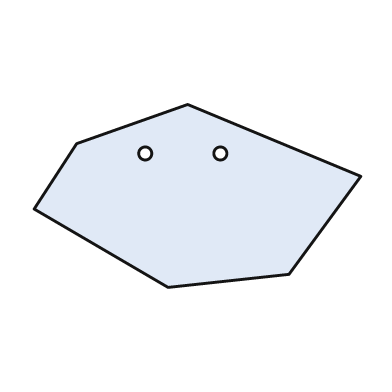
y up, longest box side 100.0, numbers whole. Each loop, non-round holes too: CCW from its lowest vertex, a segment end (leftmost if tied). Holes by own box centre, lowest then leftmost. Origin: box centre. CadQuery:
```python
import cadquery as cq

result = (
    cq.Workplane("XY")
    .moveTo(-9.0, -28.0)
    .lineTo(28.0, -24.0)
    .lineTo(50.0, 6.0)
    .lineTo(-3.0, 28.0)
    .lineTo(-37.0, 16.0)
    .lineTo(-50.0, -4.0)
    .close()
    .moveTo(-16.0, 13.0)
    .circle(2.0)
    .moveTo(7.0, 13.0)
    .circle(2.0)
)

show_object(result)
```